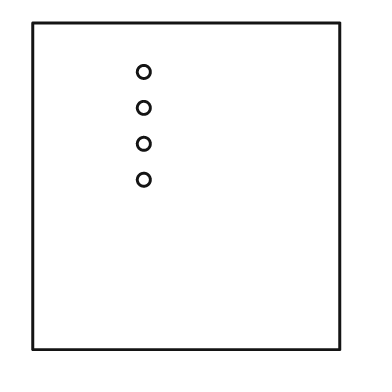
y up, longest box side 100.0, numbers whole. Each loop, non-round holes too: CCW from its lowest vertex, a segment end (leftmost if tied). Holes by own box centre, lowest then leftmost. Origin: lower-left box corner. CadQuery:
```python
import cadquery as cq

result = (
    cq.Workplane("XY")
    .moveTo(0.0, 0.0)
    .lineTo(94.0, 0.0)
    .lineTo(94.0, 100.0)
    .lineTo(0.0, 100.0)
    .close()
    .moveTo(34.0, 52.0)
    .circle(2.0)
    .moveTo(34.0, 63.0)
    .circle(2.0)
    .moveTo(34.0, 74.0)
    .circle(2.0)
    .moveTo(34.0, 85.0)
    .circle(2.0)
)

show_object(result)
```